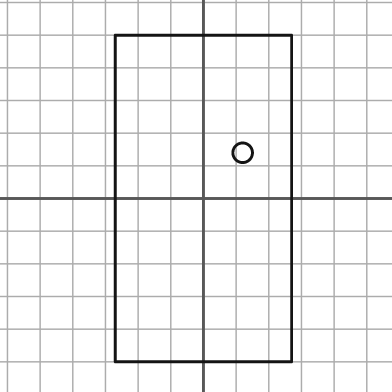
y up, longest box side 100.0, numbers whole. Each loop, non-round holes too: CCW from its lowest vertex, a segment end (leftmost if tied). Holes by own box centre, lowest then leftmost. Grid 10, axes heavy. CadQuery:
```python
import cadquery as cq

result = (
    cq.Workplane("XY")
    .moveTo(-27.0, -50.0)
    .lineTo(27.0, -50.0)
    .lineTo(27.0, 50.0)
    .lineTo(-27.0, 50.0)
    .close()
    .moveTo(12.0, 14.0)
    .circle(3.0)
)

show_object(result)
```